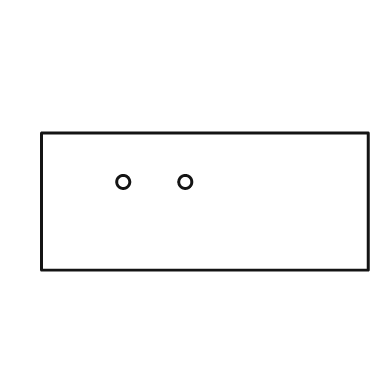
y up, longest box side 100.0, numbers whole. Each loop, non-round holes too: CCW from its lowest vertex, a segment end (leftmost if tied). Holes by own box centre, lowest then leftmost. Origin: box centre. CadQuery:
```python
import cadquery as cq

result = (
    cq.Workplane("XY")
    .moveTo(-50.0, -21.0)
    .lineTo(50.0, -21.0)
    .lineTo(50.0, 21.0)
    .lineTo(-50.0, 21.0)
    .close()
    .moveTo(-25.0, 6.0)
    .circle(2.0)
    .moveTo(-6.0, 6.0)
    .circle(2.0)
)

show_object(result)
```